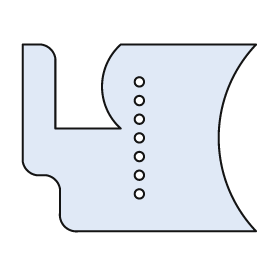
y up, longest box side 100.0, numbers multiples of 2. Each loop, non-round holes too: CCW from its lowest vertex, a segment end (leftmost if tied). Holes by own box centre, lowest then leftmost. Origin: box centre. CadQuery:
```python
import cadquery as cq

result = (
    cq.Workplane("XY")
    .moveTo(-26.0, -40.0)
    .lineTo(50.0, -40.0)
    .threePointArc((34.0, 0.0), (50.0, 40.0))
    .lineTo(-8.0, 40.0)
    .threePointArc((-16.0, 22.0), (-8.0, 4.0))
    .lineTo(-36.0, 4.0)
    .lineTo(-36.0, 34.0)
    .threePointArc((-38.0, 38.0), (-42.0, 40.0))
    .lineTo(-50.0, 40.0)
    .lineTo(-50.0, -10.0)
    .threePointArc((-48.0, -14.0), (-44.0, -16.0))
    .lineTo(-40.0, -16.0)
    .threePointArc((-36.0, -18.0), (-34.0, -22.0))
    .lineTo(-34.0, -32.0)
    .threePointArc((-32.0, -38.0), (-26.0, -40.0))
    .close()
    .moveTo(0.0, -24.0)
    .circle(2.0)
    .moveTo(0.0, -16.0)
    .circle(2.0)
    .moveTo(0.0, -8.0)
    .circle(2.0)
    .moveTo(0.0, 0.0)
    .circle(2.0)
    .moveTo(0.0, 8.0)
    .circle(2.0)
    .moveTo(0.0, 16.0)
    .circle(2.0)
    .moveTo(0.0, 24.0)
    .circle(2.0)
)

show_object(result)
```